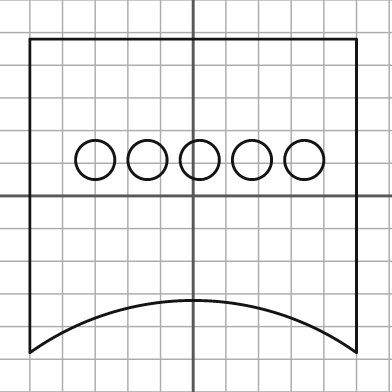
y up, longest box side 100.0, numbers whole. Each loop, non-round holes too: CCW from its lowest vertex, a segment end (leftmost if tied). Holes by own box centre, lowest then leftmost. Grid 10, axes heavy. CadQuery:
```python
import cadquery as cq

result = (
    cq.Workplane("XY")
    .moveTo(-50.0, -48.0)
    .threePointArc((0.0, -32.0), (50.0, -48.0))
    .lineTo(50.0, 48.0)
    .lineTo(-50.0, 48.0)
    .close()
    .moveTo(-30.0, 11.0)
    .circle(6.0)
    .moveTo(-14.0, 11.0)
    .circle(6.0)
    .moveTo(2.0, 11.0)
    .circle(6.0)
    .moveTo(18.0, 11.0)
    .circle(6.0)
    .moveTo(34.0, 11.0)
    .circle(6.0)
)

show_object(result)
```